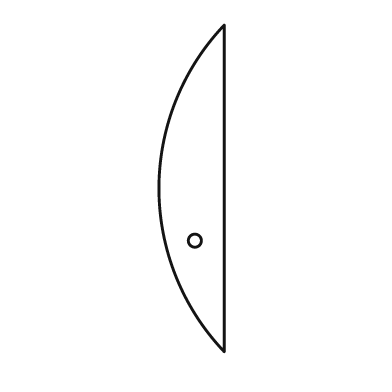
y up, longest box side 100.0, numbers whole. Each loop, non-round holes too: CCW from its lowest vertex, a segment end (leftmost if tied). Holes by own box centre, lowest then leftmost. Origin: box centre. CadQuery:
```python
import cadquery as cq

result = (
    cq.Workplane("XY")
    .moveTo(10.0, -50.0)
    .lineTo(10.0, 50.0)
    .threePointArc((-10.0, 0.0), (10.0, -50.0))
    .close()
    .moveTo(1.0, -16.0)
    .circle(2.0)
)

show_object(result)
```